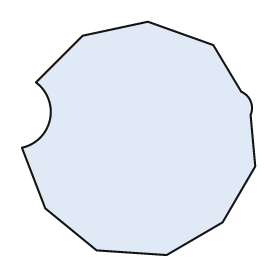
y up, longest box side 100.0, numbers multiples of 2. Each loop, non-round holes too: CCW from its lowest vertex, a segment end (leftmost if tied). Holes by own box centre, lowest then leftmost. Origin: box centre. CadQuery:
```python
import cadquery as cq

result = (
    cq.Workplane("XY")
    .moveTo(12.0, -50.0)
    .lineTo(36.0, -36.0)
    .lineTo(50.0, -12.0)
    .lineTo(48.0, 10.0)
    .threePointArc((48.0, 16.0), (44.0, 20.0))
    .lineTo(32.0, 40.0)
    .lineTo(4.0, 50.0)
    .lineTo(-24.0, 44.0)
    .lineTo(-44.0, 24.0)
    .threePointArc((-38.0, 8.0), (-50.0, -4.0))
    .lineTo(-40.0, -30.0)
    .lineTo(-18.0, -48.0)
    .close()
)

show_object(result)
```